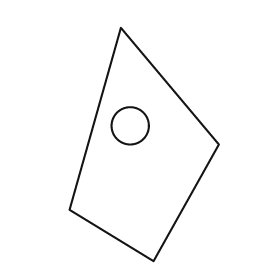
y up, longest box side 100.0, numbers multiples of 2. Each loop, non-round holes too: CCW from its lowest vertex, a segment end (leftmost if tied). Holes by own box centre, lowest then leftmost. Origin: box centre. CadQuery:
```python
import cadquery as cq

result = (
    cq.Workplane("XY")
    .moveTo(4.0, -50.0)
    .lineTo(32.0, 0.0)
    .lineTo(-10.0, 50.0)
    .lineTo(-32.0, -28.0)
    .close()
    .moveTo(-6.0, 8.0)
    .circle(8.0)
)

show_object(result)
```